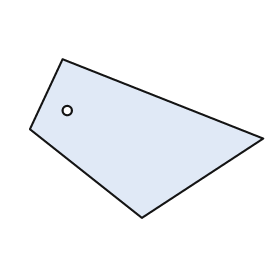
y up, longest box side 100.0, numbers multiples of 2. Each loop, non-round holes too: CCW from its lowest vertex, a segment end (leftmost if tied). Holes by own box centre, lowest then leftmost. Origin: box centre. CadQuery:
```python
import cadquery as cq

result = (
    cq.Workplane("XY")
    .moveTo(-2.0, -34.0)
    .lineTo(50.0, 0.0)
    .lineTo(-36.0, 34.0)
    .lineTo(-50.0, 4.0)
    .close()
    .moveTo(-34.0, 12.0)
    .circle(2.0)
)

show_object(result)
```